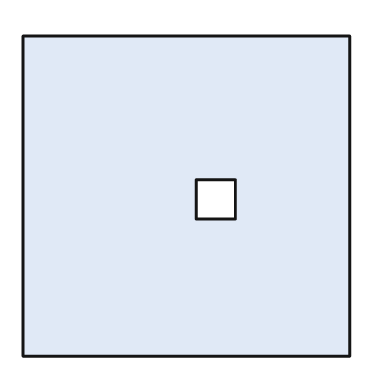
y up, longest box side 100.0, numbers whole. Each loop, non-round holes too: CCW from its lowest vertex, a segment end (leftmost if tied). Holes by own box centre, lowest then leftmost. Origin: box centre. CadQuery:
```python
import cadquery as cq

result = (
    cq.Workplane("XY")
    .moveTo(-50.0, -49.0)
    .lineTo(50.0, -49.0)
    .lineTo(50.0, 49.0)
    .lineTo(-50.0, 49.0)
    .close()
    .moveTo(3.0, -7.0)
    .lineTo(15.0, -7.0)
    .lineTo(15.0, 5.0)
    .lineTo(3.0, 5.0)
    .close()
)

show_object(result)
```